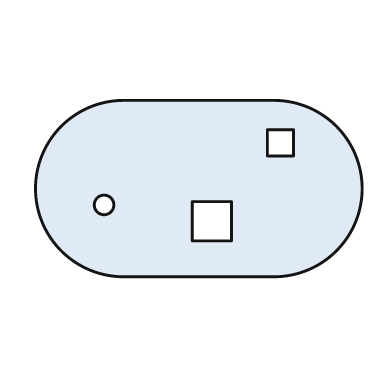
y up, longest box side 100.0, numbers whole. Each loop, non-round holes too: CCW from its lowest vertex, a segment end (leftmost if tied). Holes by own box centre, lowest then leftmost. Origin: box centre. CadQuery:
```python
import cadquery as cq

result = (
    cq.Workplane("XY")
    .moveTo(-23.0, -27.0)
    .lineTo(23.0, -27.0)
    .threePointArc((50.0, 0.0), (23.0, 27.0))
    .lineTo(-23.0, 27.0)
    .threePointArc((-50.0, 0.0), (-23.0, -27.0))
    .close()
    .moveTo(-2.0, -16.0)
    .lineTo(10.0, -16.0)
    .lineTo(10.0, -4.0)
    .lineTo(-2.0, -4.0)
    .close()
    .moveTo(-29.0, -5.0)
    .circle(3.0)
    .moveTo(21.0, 10.0)
    .lineTo(29.0, 10.0)
    .lineTo(29.0, 18.0)
    .lineTo(21.0, 18.0)
    .close()
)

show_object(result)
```